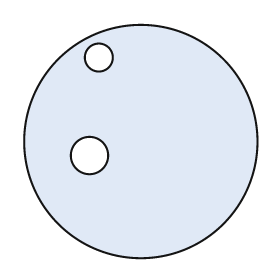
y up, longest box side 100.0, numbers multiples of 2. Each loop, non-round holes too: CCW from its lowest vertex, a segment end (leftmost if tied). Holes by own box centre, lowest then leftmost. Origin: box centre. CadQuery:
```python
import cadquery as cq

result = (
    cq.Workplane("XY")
    .moveTo(0.0, 0.0)
    .circle(50.0)
    .moveTo(-22.0, -6.0)
    .circle(8.0)
    .moveTo(-18.0, 36.0)
    .circle(6.0)
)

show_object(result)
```